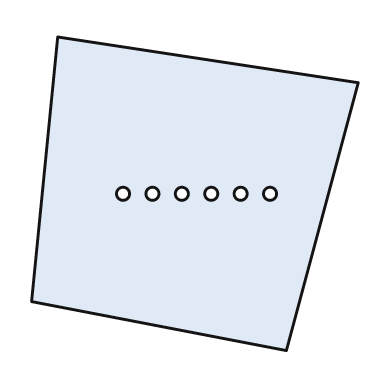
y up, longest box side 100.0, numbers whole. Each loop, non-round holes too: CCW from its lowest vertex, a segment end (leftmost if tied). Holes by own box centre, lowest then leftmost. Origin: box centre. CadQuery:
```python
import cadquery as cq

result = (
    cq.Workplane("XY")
    .moveTo(28.0, -48.0)
    .lineTo(50.0, 34.0)
    .lineTo(-42.0, 48.0)
    .lineTo(-50.0, -33.0)
    .close()
    .moveTo(-22.0, 0.0)
    .circle(2.0)
    .moveTo(-13.0, 0.0)
    .circle(2.0)
    .moveTo(-4.0, 0.0)
    .circle(2.0)
    .moveTo(5.0, 0.0)
    .circle(2.0)
    .moveTo(14.0, 0.0)
    .circle(2.0)
    .moveTo(23.0, 0.0)
    .circle(2.0)
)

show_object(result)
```